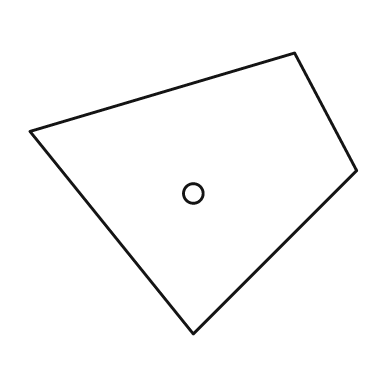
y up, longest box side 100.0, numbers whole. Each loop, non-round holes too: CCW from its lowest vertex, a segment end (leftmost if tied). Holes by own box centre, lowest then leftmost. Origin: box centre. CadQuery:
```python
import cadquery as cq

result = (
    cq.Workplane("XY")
    .moveTo(0.0, -43.0)
    .lineTo(50.0, 7.0)
    .lineTo(31.0, 43.0)
    .lineTo(-50.0, 19.0)
    .close()
    .moveTo(0.0, 0.0)
    .circle(3.0)
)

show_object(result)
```